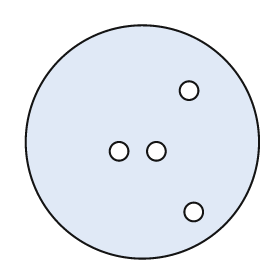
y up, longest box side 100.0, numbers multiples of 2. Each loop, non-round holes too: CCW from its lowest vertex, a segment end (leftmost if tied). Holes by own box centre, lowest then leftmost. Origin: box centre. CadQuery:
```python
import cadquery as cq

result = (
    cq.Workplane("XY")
    .moveTo(0.0, 0.0)
    .circle(50.0)
    .moveTo(22.0, -30.0)
    .circle(4.0)
    .moveTo(-10.0, -4.0)
    .circle(4.0)
    .moveTo(6.0, -4.0)
    .circle(4.0)
    .moveTo(20.0, 22.0)
    .circle(4.0)
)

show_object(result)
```